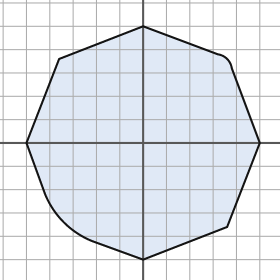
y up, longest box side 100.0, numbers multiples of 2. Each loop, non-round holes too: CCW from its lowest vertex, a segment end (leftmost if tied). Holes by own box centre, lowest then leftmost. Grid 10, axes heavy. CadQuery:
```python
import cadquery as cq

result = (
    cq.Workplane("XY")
    .moveTo(0.0, -50.0)
    .lineTo(36.0, -36.0)
    .lineTo(50.0, 0.0)
    .lineTo(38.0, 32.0)
    .threePointArc((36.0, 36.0), (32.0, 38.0))
    .lineTo(0.0, 50.0)
    .lineTo(-36.0, 36.0)
    .lineTo(-50.0, 0.0)
    .lineTo(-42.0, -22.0)
    .threePointArc((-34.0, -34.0), (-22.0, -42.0))
    .close()
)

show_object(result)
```